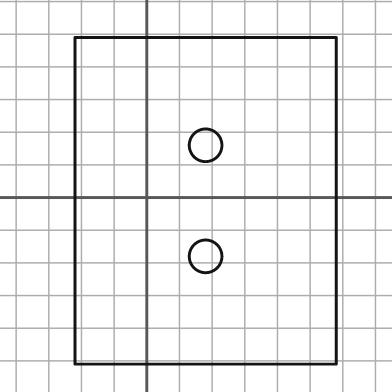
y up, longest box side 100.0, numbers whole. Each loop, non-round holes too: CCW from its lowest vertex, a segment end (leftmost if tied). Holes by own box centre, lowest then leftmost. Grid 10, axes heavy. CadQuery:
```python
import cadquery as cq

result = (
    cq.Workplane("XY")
    .moveTo(-22.0, -51.0)
    .lineTo(58.0, -51.0)
    .lineTo(58.0, 49.0)
    .lineTo(-22.0, 49.0)
    .close()
    .moveTo(18.0, -18.0)
    .circle(5.0)
    .moveTo(18.0, 16.0)
    .circle(5.0)
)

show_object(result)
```